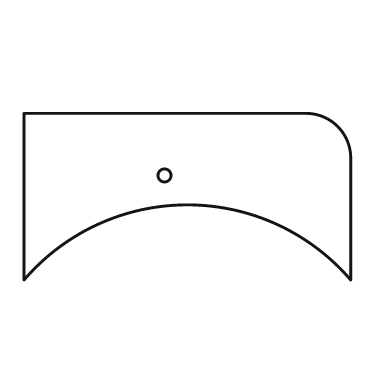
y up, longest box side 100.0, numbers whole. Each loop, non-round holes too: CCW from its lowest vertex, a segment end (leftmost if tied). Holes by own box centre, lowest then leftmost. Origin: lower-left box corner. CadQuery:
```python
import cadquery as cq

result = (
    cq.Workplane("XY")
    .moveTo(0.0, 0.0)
    .threePointArc((50.0, 23.0), (100.0, 0.0))
    .lineTo(100.0, 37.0)
    .threePointArc((96.0, 47.0), (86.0, 51.0))
    .lineTo(0.0, 51.0)
    .close()
    .moveTo(43.0, 32.0)
    .circle(2.0)
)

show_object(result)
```